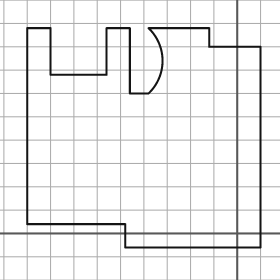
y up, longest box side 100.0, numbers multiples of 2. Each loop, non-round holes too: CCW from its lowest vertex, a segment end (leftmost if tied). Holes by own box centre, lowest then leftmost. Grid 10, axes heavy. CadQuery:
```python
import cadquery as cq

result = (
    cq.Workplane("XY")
    .moveTo(-48.0, -6.0)
    .lineTo(10.0, -6.0)
    .lineTo(10.0, 80.0)
    .lineTo(-12.0, 80.0)
    .lineTo(-12.0, 88.0)
    .lineTo(-38.0, 88.0)
    .threePointArc((-32.0, 74.0), (-38.0, 60.0))
    .lineTo(-46.0, 60.0)
    .lineTo(-46.0, 88.0)
    .lineTo(-56.0, 88.0)
    .lineTo(-56.0, 68.0)
    .lineTo(-80.0, 68.0)
    .lineTo(-80.0, 88.0)
    .lineTo(-90.0, 88.0)
    .lineTo(-90.0, 4.0)
    .lineTo(-48.0, 4.0)
    .close()
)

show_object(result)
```